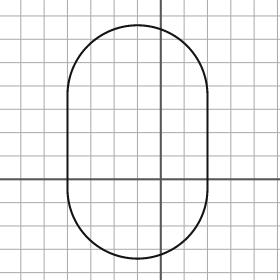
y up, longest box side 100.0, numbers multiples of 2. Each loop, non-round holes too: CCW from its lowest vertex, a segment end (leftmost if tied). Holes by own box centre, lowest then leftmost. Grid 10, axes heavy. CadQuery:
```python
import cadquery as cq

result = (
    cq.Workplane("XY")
    .moveTo(-40.0, -4.0)
    .threePointArc((-10.0, -34.0), (20.0, -4.0))
    .lineTo(20.0, 36.0)
    .threePointArc((-10.0, 66.0), (-40.0, 36.0))
    .close()
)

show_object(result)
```